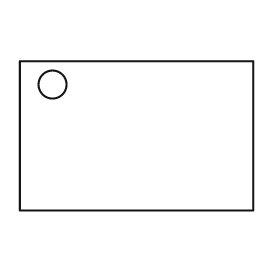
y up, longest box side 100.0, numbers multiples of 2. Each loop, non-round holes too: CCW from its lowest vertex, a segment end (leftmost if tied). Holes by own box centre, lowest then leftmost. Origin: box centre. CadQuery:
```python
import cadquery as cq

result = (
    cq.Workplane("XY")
    .moveTo(-50.0, -32.0)
    .lineTo(50.0, -32.0)
    .lineTo(50.0, 32.0)
    .lineTo(-50.0, 32.0)
    .close()
    .moveTo(-36.0, 22.0)
    .circle(6.0)
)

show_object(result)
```